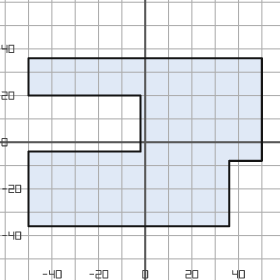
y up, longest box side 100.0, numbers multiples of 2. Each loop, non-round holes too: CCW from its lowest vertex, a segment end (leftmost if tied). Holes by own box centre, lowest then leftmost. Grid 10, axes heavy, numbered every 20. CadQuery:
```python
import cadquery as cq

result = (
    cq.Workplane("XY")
    .moveTo(-50.0, -36.0)
    .lineTo(36.0, -36.0)
    .lineTo(36.0, -8.0)
    .lineTo(50.0, -8.0)
    .lineTo(50.0, 36.0)
    .lineTo(-50.0, 36.0)
    .lineTo(-50.0, 20.0)
    .lineTo(-2.0, 20.0)
    .lineTo(-2.0, -4.0)
    .lineTo(-50.0, -4.0)
    .close()
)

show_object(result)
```